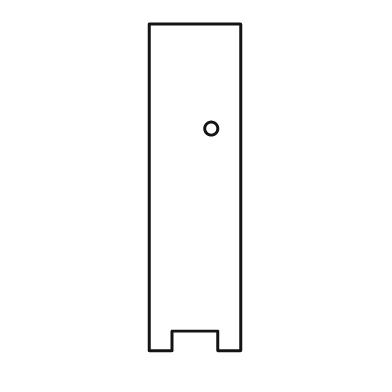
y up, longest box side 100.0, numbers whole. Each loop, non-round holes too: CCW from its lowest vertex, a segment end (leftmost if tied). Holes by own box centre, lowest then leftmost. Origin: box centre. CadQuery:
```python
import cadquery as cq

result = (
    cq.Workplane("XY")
    .moveTo(-14.0, -50.0)
    .lineTo(-7.0, -50.0)
    .lineTo(-7.0, -44.0)
    .lineTo(7.0, -44.0)
    .lineTo(7.0, -50.0)
    .lineTo(14.0, -50.0)
    .lineTo(14.0, 50.0)
    .lineTo(-14.0, 50.0)
    .close()
    .moveTo(5.0, 18.0)
    .circle(2.0)
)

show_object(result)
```